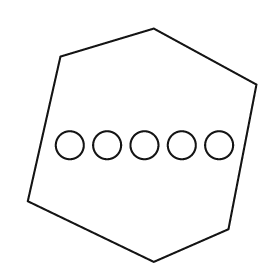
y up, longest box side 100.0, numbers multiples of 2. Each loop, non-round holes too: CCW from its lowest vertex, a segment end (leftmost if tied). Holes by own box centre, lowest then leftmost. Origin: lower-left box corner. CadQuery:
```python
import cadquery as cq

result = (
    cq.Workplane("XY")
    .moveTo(54.0, 0.0)
    .lineTo(86.0, 14.0)
    .lineTo(98.0, 76.0)
    .lineTo(54.0, 100.0)
    .lineTo(14.0, 88.0)
    .lineTo(0.0, 26.0)
    .close()
    .moveTo(18.0, 50.0)
    .circle(6.0)
    .moveTo(34.0, 50.0)
    .circle(6.0)
    .moveTo(50.0, 50.0)
    .circle(6.0)
    .moveTo(66.0, 50.0)
    .circle(6.0)
    .moveTo(82.0, 50.0)
    .circle(6.0)
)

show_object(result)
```